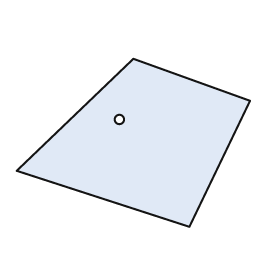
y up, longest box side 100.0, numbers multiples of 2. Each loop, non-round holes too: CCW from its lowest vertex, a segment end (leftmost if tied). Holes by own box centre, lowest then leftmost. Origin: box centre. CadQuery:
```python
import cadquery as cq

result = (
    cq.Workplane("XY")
    .moveTo(24.0, -36.0)
    .lineTo(50.0, 18.0)
    .lineTo(0.0, 36.0)
    .lineTo(-50.0, -12.0)
    .close()
    .moveTo(-6.0, 10.0)
    .circle(2.0)
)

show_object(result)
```